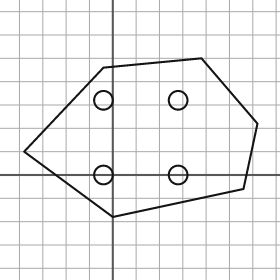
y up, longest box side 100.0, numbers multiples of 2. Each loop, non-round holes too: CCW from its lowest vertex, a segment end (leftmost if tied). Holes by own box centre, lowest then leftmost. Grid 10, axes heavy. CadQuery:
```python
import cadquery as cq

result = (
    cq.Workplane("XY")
    .moveTo(0.0, -18.0)
    .lineTo(56.0, -6.0)
    .lineTo(62.0, 22.0)
    .lineTo(38.0, 50.0)
    .lineTo(-4.0, 46.0)
    .lineTo(-38.0, 10.0)
    .close()
    .moveTo(-4.0, 0.0)
    .circle(4.0)
    .moveTo(28.0, 0.0)
    .circle(4.0)
    .moveTo(-4.0, 32.0)
    .circle(4.0)
    .moveTo(28.0, 32.0)
    .circle(4.0)
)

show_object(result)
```